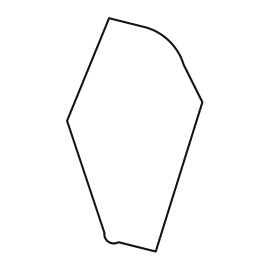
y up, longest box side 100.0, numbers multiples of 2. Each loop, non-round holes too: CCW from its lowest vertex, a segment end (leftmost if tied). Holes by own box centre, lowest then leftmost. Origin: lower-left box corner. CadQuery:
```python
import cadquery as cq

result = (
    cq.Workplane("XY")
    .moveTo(38.0, 0.0)
    .lineTo(58.0, 64.0)
    .lineTo(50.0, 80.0)
    .threePointArc((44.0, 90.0), (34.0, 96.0))
    .lineTo(18.0, 100.0)
    .lineTo(0.0, 56.0)
    .lineTo(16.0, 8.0)
    .threePointArc((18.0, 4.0), (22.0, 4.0))
    .close()
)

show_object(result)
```